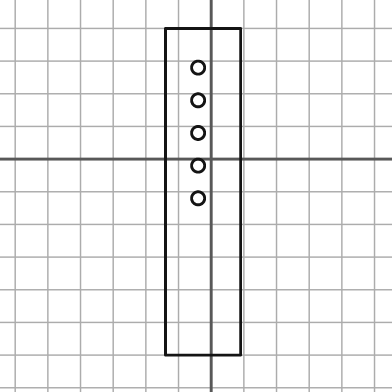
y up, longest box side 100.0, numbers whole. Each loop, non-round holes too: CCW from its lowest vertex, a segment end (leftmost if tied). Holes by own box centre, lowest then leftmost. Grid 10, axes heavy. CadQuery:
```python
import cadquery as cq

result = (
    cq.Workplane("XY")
    .moveTo(-14.0, -60.0)
    .lineTo(9.0, -60.0)
    .lineTo(9.0, 40.0)
    .lineTo(-14.0, 40.0)
    .close()
    .moveTo(-4.0, -12.0)
    .circle(2.0)
    .moveTo(-4.0, -2.0)
    .circle(2.0)
    .moveTo(-4.0, 8.0)
    .circle(2.0)
    .moveTo(-4.0, 18.0)
    .circle(2.0)
    .moveTo(-4.0, 28.0)
    .circle(2.0)
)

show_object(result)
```